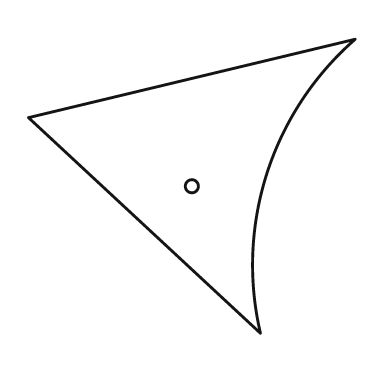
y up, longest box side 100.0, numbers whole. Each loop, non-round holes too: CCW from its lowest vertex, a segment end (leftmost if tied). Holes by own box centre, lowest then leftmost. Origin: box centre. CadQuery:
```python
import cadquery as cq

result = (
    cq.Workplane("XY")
    .moveTo(21.0, -45.0)
    .threePointArc((23.0, 4.0), (50.0, 45.0))
    .lineTo(-50.0, 21.0)
    .close()
    .moveTo(0.0, 0.0)
    .circle(2.0)
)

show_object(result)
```